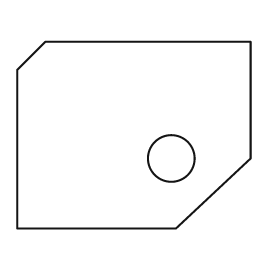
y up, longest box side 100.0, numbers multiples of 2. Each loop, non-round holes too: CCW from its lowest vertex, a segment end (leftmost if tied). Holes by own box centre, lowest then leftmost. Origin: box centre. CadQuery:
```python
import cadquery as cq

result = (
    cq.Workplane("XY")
    .moveTo(-50.0, -40.0)
    .lineTo(18.0, -40.0)
    .lineTo(50.0, -10.0)
    .lineTo(50.0, 40.0)
    .lineTo(-38.0, 40.0)
    .lineTo(-50.0, 28.0)
    .close()
    .moveTo(16.0, -10.0)
    .circle(10.0)
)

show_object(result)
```